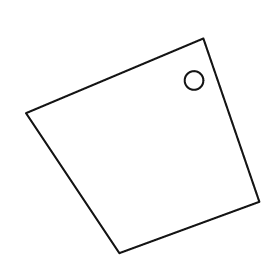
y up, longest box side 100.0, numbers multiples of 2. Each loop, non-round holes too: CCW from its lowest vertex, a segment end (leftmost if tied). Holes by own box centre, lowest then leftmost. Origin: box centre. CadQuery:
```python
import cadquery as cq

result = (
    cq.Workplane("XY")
    .moveTo(-10.0, -46.0)
    .lineTo(50.0, -24.0)
    .lineTo(26.0, 46.0)
    .lineTo(-50.0, 14.0)
    .close()
    .moveTo(22.0, 28.0)
    .circle(4.0)
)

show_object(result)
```